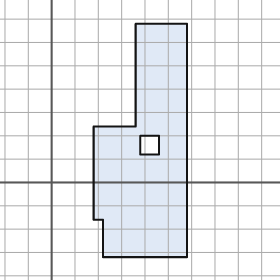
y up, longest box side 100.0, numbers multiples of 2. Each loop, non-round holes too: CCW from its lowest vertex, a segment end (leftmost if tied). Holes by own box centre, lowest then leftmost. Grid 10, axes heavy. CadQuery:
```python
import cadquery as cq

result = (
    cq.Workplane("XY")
    .moveTo(22.0, -32.0)
    .lineTo(58.0, -32.0)
    .lineTo(58.0, 68.0)
    .lineTo(36.0, 68.0)
    .lineTo(36.0, 24.0)
    .lineTo(18.0, 24.0)
    .lineTo(18.0, -16.0)
    .lineTo(22.0, -16.0)
    .close()
    .moveTo(38.0, 12.0)
    .lineTo(46.0, 12.0)
    .lineTo(46.0, 20.0)
    .lineTo(38.0, 20.0)
    .close()
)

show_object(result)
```